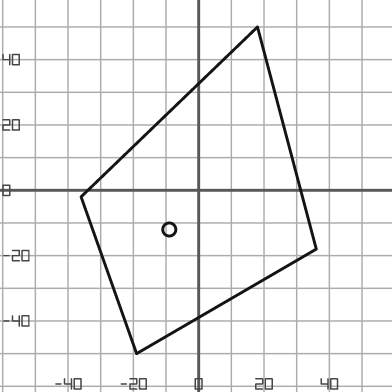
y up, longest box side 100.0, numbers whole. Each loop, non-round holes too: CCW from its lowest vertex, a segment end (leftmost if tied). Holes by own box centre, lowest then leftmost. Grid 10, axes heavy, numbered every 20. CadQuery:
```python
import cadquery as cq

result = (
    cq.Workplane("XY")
    .moveTo(-19.0, -50.0)
    .lineTo(36.0, -18.0)
    .lineTo(18.0, 50.0)
    .lineTo(-36.0, -2.0)
    .close()
    .moveTo(-9.0, -12.0)
    .circle(2.0)
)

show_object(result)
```